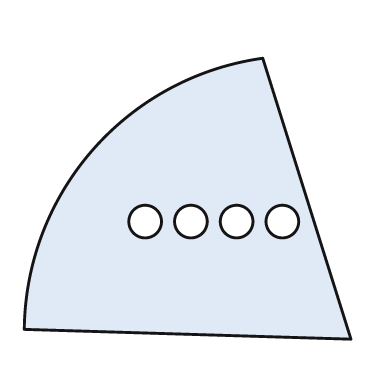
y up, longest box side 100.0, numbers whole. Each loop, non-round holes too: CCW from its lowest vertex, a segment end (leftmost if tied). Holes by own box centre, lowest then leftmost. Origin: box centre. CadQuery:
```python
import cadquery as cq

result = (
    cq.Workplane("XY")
    .moveTo(50.0, -43.0)
    .lineTo(23.0, 43.0)
    .threePointArc((-29.0, 15.0), (-50.0, -40.0))
    .close()
    .moveTo(-13.0, -7.0)
    .circle(5.0)
    .moveTo(1.0, -7.0)
    .circle(5.0)
    .moveTo(15.0, -7.0)
    .circle(5.0)
    .moveTo(29.0, -7.0)
    .circle(5.0)
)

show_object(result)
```